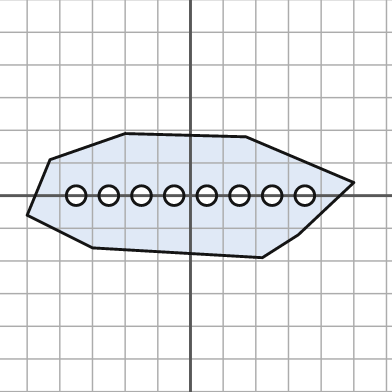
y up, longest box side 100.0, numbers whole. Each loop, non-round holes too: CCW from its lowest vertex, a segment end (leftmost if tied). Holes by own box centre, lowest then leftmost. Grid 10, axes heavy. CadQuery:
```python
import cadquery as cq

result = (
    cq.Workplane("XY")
    .moveTo(22.0, -19.0)
    .lineTo(33.0, -12.0)
    .lineTo(50.0, 4.0)
    .lineTo(17.0, 18.0)
    .lineTo(-20.0, 19.0)
    .lineTo(-43.0, 11.0)
    .lineTo(-50.0, -6.0)
    .lineTo(-30.0, -16.0)
    .close()
    .moveTo(-35.0, 0.0)
    .circle(3.0)
    .moveTo(-25.0, 0.0)
    .circle(3.0)
    .moveTo(-15.0, 0.0)
    .circle(3.0)
    .moveTo(-5.0, 0.0)
    .circle(3.0)
    .moveTo(5.0, 0.0)
    .circle(3.0)
    .moveTo(15.0, 0.0)
    .circle(3.0)
    .moveTo(25.0, 0.0)
    .circle(3.0)
    .moveTo(35.0, 0.0)
    .circle(3.0)
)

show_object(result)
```